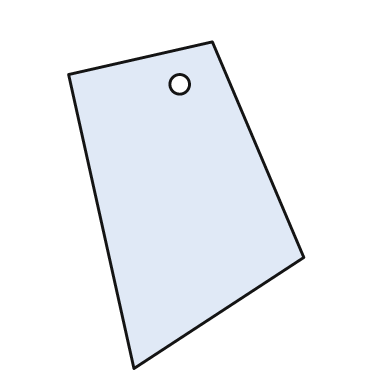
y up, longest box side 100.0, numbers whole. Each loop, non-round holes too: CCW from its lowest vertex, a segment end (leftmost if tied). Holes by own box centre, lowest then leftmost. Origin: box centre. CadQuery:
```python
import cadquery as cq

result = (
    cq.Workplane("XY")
    .moveTo(-16.0, -50.0)
    .lineTo(36.0, -16.0)
    .lineTo(8.0, 50.0)
    .lineTo(-36.0, 40.0)
    .close()
    .moveTo(-2.0, 37.0)
    .circle(3.0)
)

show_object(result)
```